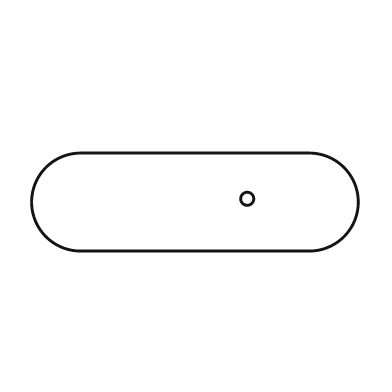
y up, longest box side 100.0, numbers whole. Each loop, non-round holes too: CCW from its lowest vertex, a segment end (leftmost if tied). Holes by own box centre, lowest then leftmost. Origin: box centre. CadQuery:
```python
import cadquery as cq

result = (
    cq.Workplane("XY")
    .moveTo(-35.0, -15.0)
    .lineTo(35.0, -15.0)
    .threePointArc((50.0, 0.0), (35.0, 15.0))
    .lineTo(-35.0, 15.0)
    .threePointArc((-50.0, 0.0), (-35.0, -15.0))
    .close()
    .moveTo(16.0, 1.0)
    .circle(2.0)
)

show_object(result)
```